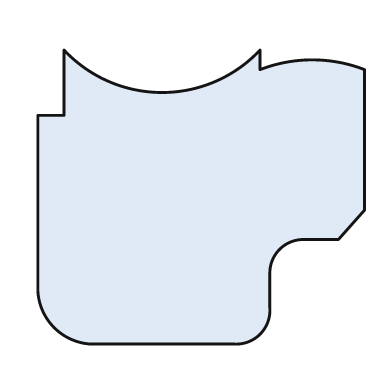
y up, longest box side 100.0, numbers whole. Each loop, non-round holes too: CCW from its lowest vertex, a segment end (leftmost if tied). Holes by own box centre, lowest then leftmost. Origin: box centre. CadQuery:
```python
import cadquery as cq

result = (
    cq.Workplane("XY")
    .moveTo(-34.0, -45.0)
    .lineTo(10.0, -45.0)
    .threePointArc((18.0, -42.0), (21.0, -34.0))
    .lineTo(21.0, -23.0)
    .threePointArc((24.0, -16.0), (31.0, -13.0))
    .lineTo(42.0, -13.0)
    .lineTo(50.0, -4.0)
    .lineTo(50.0, 39.0)
    .threePointArc((34.0, 42.0), (18.0, 39.0))
    .lineTo(18.0, 45.0)
    .threePointArc((-12.0, 32.0), (-42.0, 45.0))
    .lineTo(-42.0, 25.0)
    .lineTo(-50.0, 25.0)
    .lineTo(-50.0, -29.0)
    .threePointArc((-45.0, -40.0), (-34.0, -45.0))
    .close()
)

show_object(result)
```